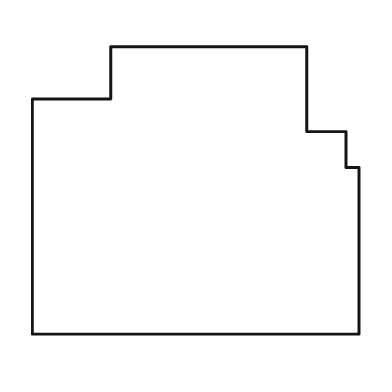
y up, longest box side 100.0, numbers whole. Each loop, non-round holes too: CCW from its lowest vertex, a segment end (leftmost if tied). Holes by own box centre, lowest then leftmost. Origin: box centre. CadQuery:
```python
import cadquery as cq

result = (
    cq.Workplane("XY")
    .moveTo(-50.0, -44.0)
    .lineTo(50.0, -44.0)
    .lineTo(50.0, 7.0)
    .lineTo(46.0, 7.0)
    .lineTo(46.0, 18.0)
    .lineTo(34.0, 18.0)
    .lineTo(34.0, 44.0)
    .lineTo(-26.0, 44.0)
    .lineTo(-26.0, 28.0)
    .lineTo(-50.0, 28.0)
    .close()
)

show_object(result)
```